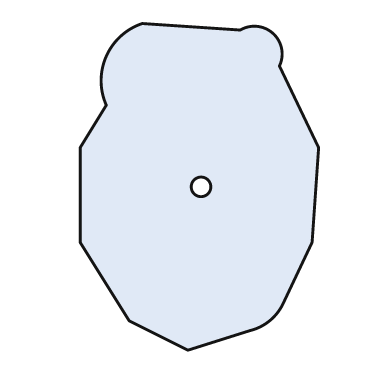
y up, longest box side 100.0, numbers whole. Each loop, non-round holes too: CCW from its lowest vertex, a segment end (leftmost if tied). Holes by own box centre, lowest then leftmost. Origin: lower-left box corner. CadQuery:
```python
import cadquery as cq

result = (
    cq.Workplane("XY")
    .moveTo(33.0, 0.0)
    .lineTo(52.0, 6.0)
    .threePointArc((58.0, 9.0), (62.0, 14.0))
    .lineTo(71.0, 33.0)
    .lineTo(73.0, 62.0)
    .lineTo(61.0, 87.0)
    .threePointArc((59.0, 97.0), (49.0, 98.0))
    .lineTo(19.0, 100.0)
    .threePointArc((8.0, 90.0), (8.0, 75.0))
    .lineTo(0.0, 62.0)
    .lineTo(0.0, 33.0)
    .lineTo(15.0, 9.0)
    .close()
    .moveTo(37.0, 50.0)
    .circle(3.0)
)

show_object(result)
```